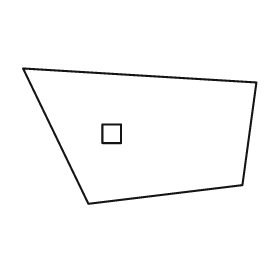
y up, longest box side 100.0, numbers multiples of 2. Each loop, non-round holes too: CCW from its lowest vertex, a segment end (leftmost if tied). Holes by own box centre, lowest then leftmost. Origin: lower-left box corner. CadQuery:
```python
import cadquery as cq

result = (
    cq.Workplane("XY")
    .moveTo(28.0, 0.0)
    .lineTo(94.0, 8.0)
    .lineTo(100.0, 52.0)
    .lineTo(0.0, 58.0)
    .close()
    .moveTo(34.0, 26.0)
    .lineTo(42.0, 26.0)
    .lineTo(42.0, 34.0)
    .lineTo(34.0, 34.0)
    .close()
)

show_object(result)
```